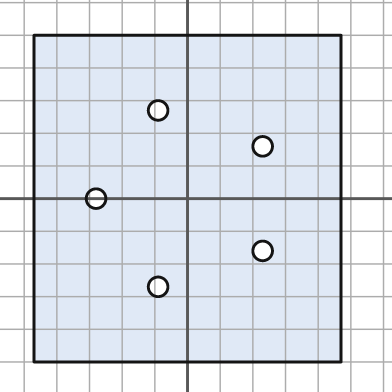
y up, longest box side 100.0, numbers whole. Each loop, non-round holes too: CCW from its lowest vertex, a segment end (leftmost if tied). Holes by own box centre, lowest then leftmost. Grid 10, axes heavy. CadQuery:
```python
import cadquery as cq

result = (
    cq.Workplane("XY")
    .moveTo(-47.0, -50.0)
    .lineTo(47.0, -50.0)
    .lineTo(47.0, 50.0)
    .lineTo(-47.0, 50.0)
    .close()
    .moveTo(-9.0, -27.0)
    .circle(3.0)
    .moveTo(23.0, -16.0)
    .circle(3.0)
    .moveTo(-28.0, 0.0)
    .circle(3.0)
    .moveTo(23.0, 16.0)
    .circle(3.0)
    .moveTo(-9.0, 27.0)
    .circle(3.0)
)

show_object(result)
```